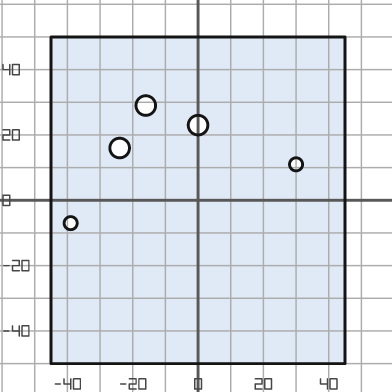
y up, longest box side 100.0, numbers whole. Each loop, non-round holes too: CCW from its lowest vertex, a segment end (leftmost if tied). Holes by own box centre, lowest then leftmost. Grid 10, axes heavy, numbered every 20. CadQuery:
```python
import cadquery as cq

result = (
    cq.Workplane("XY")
    .moveTo(-45.0, -50.0)
    .lineTo(45.0, -50.0)
    .lineTo(45.0, 50.0)
    .lineTo(-45.0, 50.0)
    .close()
    .moveTo(-39.0, -7.0)
    .circle(2.0)
    .moveTo(30.0, 11.0)
    .circle(2.0)
    .moveTo(-24.0, 16.0)
    .circle(3.0)
    .moveTo(0.0, 23.0)
    .circle(3.0)
    .moveTo(-16.0, 29.0)
    .circle(3.0)
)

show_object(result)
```